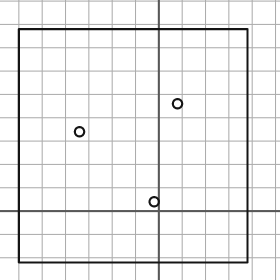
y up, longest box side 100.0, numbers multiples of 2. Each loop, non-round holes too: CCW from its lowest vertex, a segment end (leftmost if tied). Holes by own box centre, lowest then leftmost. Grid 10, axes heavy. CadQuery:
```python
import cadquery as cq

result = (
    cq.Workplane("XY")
    .moveTo(-60.0, -22.0)
    .lineTo(38.0, -22.0)
    .lineTo(38.0, 78.0)
    .lineTo(-60.0, 78.0)
    .close()
    .moveTo(-2.0, 4.0)
    .circle(2.0)
    .moveTo(-34.0, 34.0)
    .circle(2.0)
    .moveTo(8.0, 46.0)
    .circle(2.0)
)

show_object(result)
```